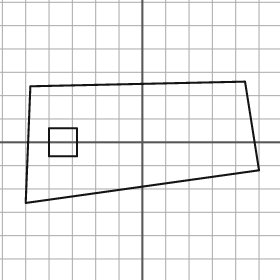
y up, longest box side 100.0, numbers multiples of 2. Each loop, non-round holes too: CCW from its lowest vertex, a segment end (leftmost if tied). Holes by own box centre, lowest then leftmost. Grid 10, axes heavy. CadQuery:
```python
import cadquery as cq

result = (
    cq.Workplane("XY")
    .moveTo(-50.0, -26.0)
    .lineTo(50.0, -12.0)
    .lineTo(44.0, 26.0)
    .lineTo(-48.0, 24.0)
    .close()
    .moveTo(-40.0, -6.0)
    .lineTo(-28.0, -6.0)
    .lineTo(-28.0, 6.0)
    .lineTo(-40.0, 6.0)
    .close()
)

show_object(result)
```